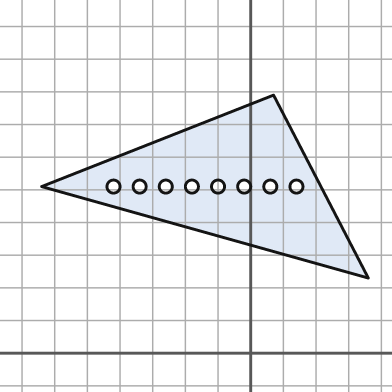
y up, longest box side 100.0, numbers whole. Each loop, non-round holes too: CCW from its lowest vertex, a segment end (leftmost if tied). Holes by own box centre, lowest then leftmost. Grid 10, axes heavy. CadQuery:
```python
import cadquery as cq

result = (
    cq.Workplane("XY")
    .moveTo(36.0, 23.0)
    .lineTo(7.0, 79.0)
    .lineTo(-64.0, 51.0)
    .close()
    .moveTo(-42.0, 51.0)
    .circle(2.0)
    .moveTo(-34.0, 51.0)
    .circle(2.0)
    .moveTo(-26.0, 51.0)
    .circle(2.0)
    .moveTo(-18.0, 51.0)
    .circle(2.0)
    .moveTo(-10.0, 51.0)
    .circle(2.0)
    .moveTo(-2.0, 51.0)
    .circle(2.0)
    .moveTo(6.0, 51.0)
    .circle(2.0)
    .moveTo(14.0, 51.0)
    .circle(2.0)
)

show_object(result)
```